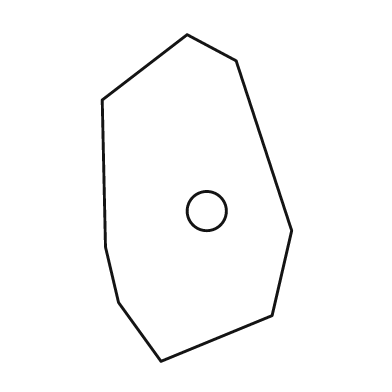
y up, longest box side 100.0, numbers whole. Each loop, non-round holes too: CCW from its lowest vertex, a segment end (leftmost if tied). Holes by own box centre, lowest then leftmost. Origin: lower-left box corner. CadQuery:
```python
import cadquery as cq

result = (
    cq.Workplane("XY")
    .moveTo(18.0, 0.0)
    .lineTo(52.0, 14.0)
    .lineTo(58.0, 40.0)
    .lineTo(41.0, 92.0)
    .lineTo(26.0, 100.0)
    .lineTo(0.0, 80.0)
    .lineTo(1.0, 35.0)
    .lineTo(5.0, 18.0)
    .close()
    .moveTo(32.0, 46.0)
    .circle(6.0)
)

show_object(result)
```